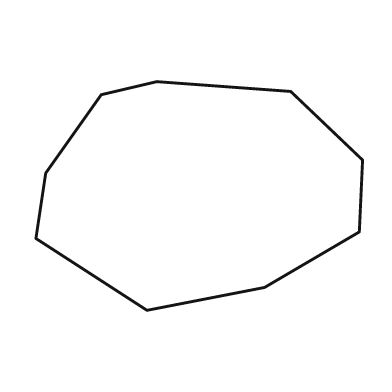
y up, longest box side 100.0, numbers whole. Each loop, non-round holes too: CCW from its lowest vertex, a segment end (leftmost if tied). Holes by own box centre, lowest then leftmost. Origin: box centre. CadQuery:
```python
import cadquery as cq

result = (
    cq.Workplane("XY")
    .moveTo(-16.0, -35.0)
    .lineTo(20.0, -28.0)
    .lineTo(49.0, -11.0)
    .lineTo(50.0, 11.0)
    .lineTo(28.0, 32.0)
    .lineTo(-13.0, 35.0)
    .lineTo(-30.0, 31.0)
    .lineTo(-47.0, 7.0)
    .lineTo(-50.0, -13.0)
    .close()
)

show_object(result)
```